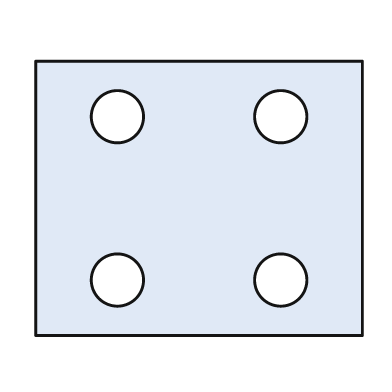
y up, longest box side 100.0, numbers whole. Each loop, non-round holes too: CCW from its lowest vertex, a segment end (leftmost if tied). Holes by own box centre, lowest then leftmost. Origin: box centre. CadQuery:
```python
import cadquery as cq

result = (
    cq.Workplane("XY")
    .moveTo(-50.0, -42.0)
    .lineTo(50.0, -42.0)
    .lineTo(50.0, 42.0)
    .lineTo(-50.0, 42.0)
    .close()
    .moveTo(-25.0, -25.0)
    .circle(8.0)
    .moveTo(25.0, -25.0)
    .circle(8.0)
    .moveTo(-25.0, 25.0)
    .circle(8.0)
    .moveTo(25.0, 25.0)
    .circle(8.0)
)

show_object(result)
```